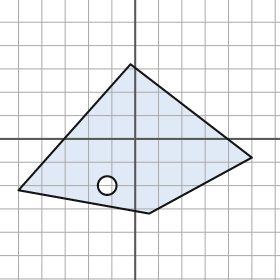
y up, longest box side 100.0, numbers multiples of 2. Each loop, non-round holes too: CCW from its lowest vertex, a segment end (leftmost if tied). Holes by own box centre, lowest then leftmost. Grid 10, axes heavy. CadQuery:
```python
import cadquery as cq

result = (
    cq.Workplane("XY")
    .moveTo(6.0, -32.0)
    .lineTo(50.0, -8.0)
    .lineTo(-2.0, 32.0)
    .lineTo(-50.0, -22.0)
    .close()
    .moveTo(-12.0, -20.0)
    .circle(4.0)
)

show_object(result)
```